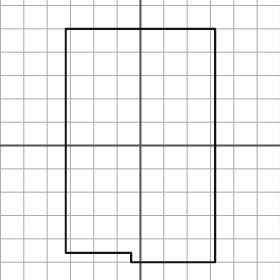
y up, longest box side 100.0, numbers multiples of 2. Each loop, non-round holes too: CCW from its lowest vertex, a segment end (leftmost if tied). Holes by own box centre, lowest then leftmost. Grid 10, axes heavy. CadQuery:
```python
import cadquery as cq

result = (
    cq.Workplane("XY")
    .moveTo(-4.0, -50.0)
    .lineTo(32.0, -50.0)
    .lineTo(32.0, 50.0)
    .lineTo(-32.0, 50.0)
    .lineTo(-32.0, -46.0)
    .lineTo(-4.0, -46.0)
    .close()
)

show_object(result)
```